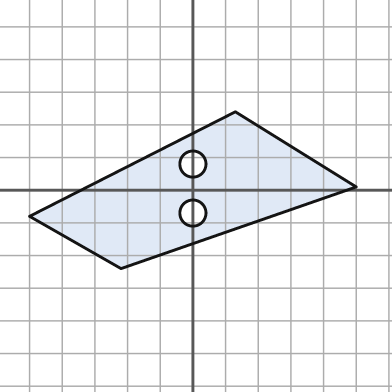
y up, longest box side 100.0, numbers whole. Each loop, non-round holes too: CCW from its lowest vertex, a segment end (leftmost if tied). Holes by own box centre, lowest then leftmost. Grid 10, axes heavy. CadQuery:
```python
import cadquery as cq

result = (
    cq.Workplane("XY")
    .moveTo(-22.0, -24.0)
    .lineTo(50.0, 1.0)
    .lineTo(13.0, 24.0)
    .lineTo(-50.0, -8.0)
    .close()
    .moveTo(0.0, -7.0)
    .circle(4.0)
    .moveTo(0.0, 8.0)
    .circle(4.0)
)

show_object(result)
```